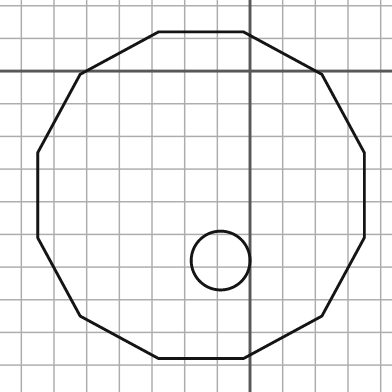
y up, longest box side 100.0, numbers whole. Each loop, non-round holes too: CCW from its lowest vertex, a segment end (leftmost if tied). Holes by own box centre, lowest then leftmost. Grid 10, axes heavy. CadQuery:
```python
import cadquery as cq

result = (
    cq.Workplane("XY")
    .moveTo(-28.0, -88.0)
    .lineTo(-2.0, -88.0)
    .lineTo(22.0, -75.0)
    .lineTo(35.0, -51.0)
    .lineTo(35.0, -25.0)
    .lineTo(22.0, -1.0)
    .lineTo(-2.0, 12.0)
    .lineTo(-28.0, 12.0)
    .lineTo(-52.0, -1.0)
    .lineTo(-65.0, -25.0)
    .lineTo(-65.0, -51.0)
    .lineTo(-52.0, -75.0)
    .close()
    .moveTo(-9.0, -58.0)
    .circle(9.0)
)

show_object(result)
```